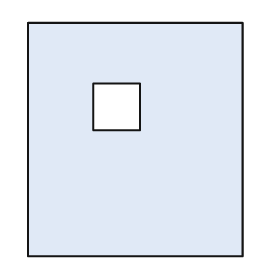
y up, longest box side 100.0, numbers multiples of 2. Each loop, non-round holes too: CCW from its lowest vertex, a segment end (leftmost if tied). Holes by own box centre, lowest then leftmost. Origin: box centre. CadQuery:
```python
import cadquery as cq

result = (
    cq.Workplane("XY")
    .moveTo(-46.0, -50.0)
    .lineTo(46.0, -50.0)
    .lineTo(46.0, 50.0)
    .lineTo(-46.0, 50.0)
    .close()
    .moveTo(-18.0, 4.0)
    .lineTo(2.0, 4.0)
    .lineTo(2.0, 24.0)
    .lineTo(-18.0, 24.0)
    .close()
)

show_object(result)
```